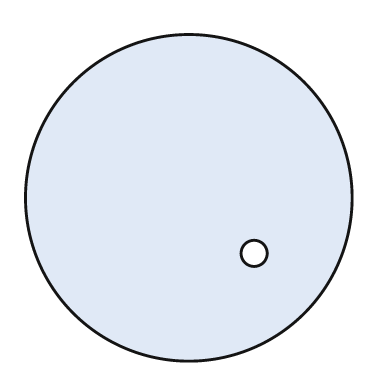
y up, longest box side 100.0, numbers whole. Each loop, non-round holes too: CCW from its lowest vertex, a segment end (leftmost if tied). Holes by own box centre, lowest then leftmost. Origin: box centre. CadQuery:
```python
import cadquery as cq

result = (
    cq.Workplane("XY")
    .moveTo(0.0, 0.0)
    .circle(50.0)
    .moveTo(20.0, -17.0)
    .circle(4.0)
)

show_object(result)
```